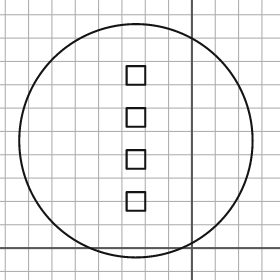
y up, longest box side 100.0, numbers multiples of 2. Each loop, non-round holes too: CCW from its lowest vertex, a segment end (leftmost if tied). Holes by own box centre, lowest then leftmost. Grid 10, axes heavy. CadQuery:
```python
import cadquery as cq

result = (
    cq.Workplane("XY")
    .moveTo(-24.0, 46.0)
    .circle(50.0)
    .moveTo(-28.0, 16.0)
    .lineTo(-20.0, 16.0)
    .lineTo(-20.0, 24.0)
    .lineTo(-28.0, 24.0)
    .close()
    .moveTo(-28.0, 34.0)
    .lineTo(-20.0, 34.0)
    .lineTo(-20.0, 42.0)
    .lineTo(-28.0, 42.0)
    .close()
    .moveTo(-28.0, 52.0)
    .lineTo(-20.0, 52.0)
    .lineTo(-20.0, 60.0)
    .lineTo(-28.0, 60.0)
    .close()
    .moveTo(-28.0, 70.0)
    .lineTo(-20.0, 70.0)
    .lineTo(-20.0, 78.0)
    .lineTo(-28.0, 78.0)
    .close()
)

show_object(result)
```